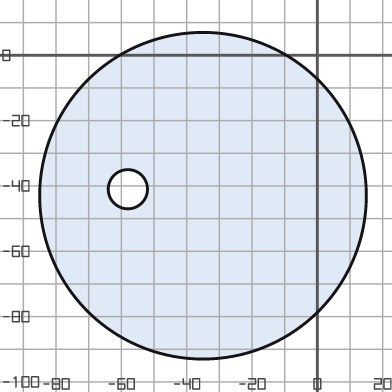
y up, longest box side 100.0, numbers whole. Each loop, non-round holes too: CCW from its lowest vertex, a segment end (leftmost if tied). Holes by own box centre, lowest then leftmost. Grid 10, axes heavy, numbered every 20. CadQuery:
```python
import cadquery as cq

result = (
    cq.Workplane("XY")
    .moveTo(-35.0, -43.0)
    .circle(50.0)
    .moveTo(-58.0, -41.0)
    .circle(6.0)
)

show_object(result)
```